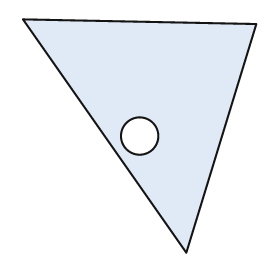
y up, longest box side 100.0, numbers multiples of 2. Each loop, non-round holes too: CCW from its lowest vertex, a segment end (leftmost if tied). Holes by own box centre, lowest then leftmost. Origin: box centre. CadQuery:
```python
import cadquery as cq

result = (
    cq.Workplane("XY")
    .moveTo(20.0, -50.0)
    .lineTo(50.0, 48.0)
    .lineTo(-50.0, 50.0)
    .close()
    .moveTo(0.0, 0.0)
    .circle(8.0)
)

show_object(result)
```